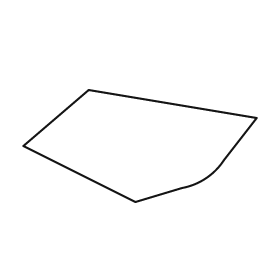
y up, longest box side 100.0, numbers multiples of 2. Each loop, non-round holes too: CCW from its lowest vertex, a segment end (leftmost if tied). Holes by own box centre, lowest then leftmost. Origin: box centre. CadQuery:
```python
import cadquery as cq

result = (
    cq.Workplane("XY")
    .moveTo(-2.0, -24.0)
    .lineTo(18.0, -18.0)
    .threePointArc((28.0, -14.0), (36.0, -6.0))
    .lineTo(50.0, 12.0)
    .lineTo(-22.0, 24.0)
    .lineTo(-50.0, 0.0)
    .close()
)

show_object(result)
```